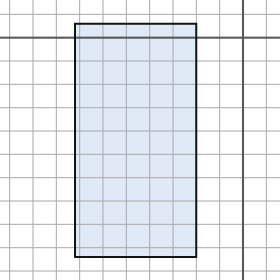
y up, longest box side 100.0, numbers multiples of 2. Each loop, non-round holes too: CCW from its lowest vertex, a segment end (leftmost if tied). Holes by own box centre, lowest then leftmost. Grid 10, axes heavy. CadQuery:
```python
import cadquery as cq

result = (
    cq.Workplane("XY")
    .moveTo(-72.0, -94.0)
    .lineTo(-20.0, -94.0)
    .lineTo(-20.0, 6.0)
    .lineTo(-72.0, 6.0)
    .close()
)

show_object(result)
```